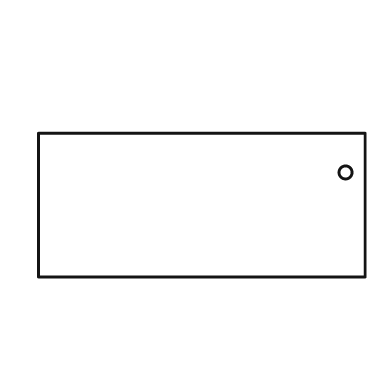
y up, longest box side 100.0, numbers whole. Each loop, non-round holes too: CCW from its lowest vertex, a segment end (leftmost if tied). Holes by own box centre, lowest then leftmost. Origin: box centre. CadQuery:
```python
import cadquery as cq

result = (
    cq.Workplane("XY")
    .moveTo(-50.0, -22.0)
    .lineTo(50.0, -22.0)
    .lineTo(50.0, 22.0)
    .lineTo(-50.0, 22.0)
    .close()
    .moveTo(44.0, 10.0)
    .circle(2.0)
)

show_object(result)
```